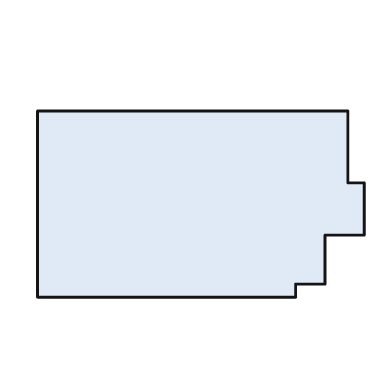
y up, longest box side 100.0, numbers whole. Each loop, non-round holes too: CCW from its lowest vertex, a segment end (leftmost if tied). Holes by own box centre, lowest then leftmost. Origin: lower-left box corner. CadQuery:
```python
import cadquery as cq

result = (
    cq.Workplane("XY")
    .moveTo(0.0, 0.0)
    .lineTo(79.0, 0.0)
    .lineTo(79.0, 4.0)
    .lineTo(88.0, 4.0)
    .lineTo(88.0, 19.0)
    .lineTo(100.0, 19.0)
    .lineTo(100.0, 35.0)
    .lineTo(95.0, 35.0)
    .lineTo(95.0, 57.0)
    .lineTo(0.0, 57.0)
    .close()
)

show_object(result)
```